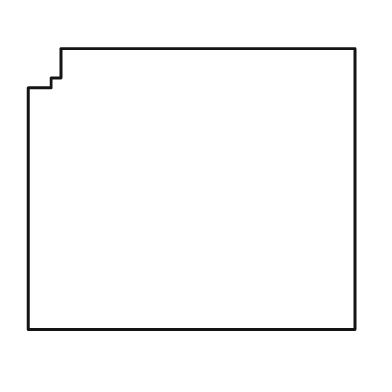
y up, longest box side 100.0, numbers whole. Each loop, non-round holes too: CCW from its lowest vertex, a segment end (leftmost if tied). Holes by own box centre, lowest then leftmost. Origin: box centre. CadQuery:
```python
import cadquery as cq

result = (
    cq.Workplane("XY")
    .moveTo(-50.0, -43.0)
    .lineTo(50.0, -43.0)
    .lineTo(50.0, 43.0)
    .lineTo(-40.0, 43.0)
    .lineTo(-40.0, 34.0)
    .lineTo(-43.0, 34.0)
    .lineTo(-43.0, 31.0)
    .lineTo(-50.0, 31.0)
    .close()
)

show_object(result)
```